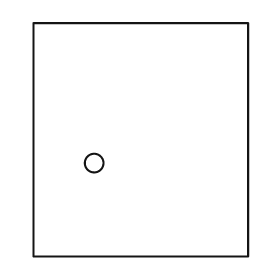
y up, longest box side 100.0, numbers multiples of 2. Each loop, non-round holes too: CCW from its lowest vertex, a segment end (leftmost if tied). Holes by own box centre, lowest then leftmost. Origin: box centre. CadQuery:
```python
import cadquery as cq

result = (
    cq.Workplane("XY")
    .moveTo(-46.0, -50.0)
    .lineTo(46.0, -50.0)
    .lineTo(46.0, 50.0)
    .lineTo(-46.0, 50.0)
    .close()
    .moveTo(-20.0, -10.0)
    .circle(4.0)
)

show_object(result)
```